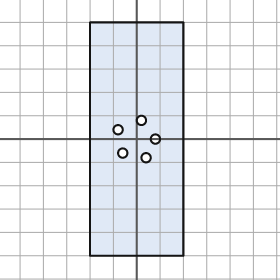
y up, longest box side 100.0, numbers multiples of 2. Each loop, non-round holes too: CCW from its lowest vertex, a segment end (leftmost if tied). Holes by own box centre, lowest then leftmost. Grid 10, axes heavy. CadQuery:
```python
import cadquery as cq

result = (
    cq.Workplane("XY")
    .moveTo(-20.0, -50.0)
    .lineTo(20.0, -50.0)
    .lineTo(20.0, 50.0)
    .lineTo(-20.0, 50.0)
    .close()
    .moveTo(4.0, -8.0)
    .circle(2.0)
    .moveTo(-6.0, -6.0)
    .circle(2.0)
    .moveTo(8.0, 0.0)
    .circle(2.0)
    .moveTo(-8.0, 4.0)
    .circle(2.0)
    .moveTo(2.0, 8.0)
    .circle(2.0)
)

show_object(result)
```